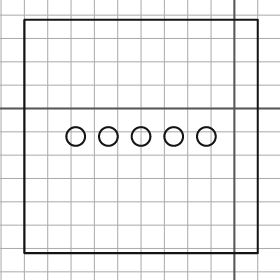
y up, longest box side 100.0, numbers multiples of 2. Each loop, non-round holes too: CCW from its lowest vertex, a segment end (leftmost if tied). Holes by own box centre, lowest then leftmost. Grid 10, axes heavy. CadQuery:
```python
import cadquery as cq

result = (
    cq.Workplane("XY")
    .moveTo(-90.0, -62.0)
    .lineTo(10.0, -62.0)
    .lineTo(10.0, 38.0)
    .lineTo(-90.0, 38.0)
    .close()
    .moveTo(-68.0, -12.0)
    .circle(4.0)
    .moveTo(-54.0, -12.0)
    .circle(4.0)
    .moveTo(-40.0, -12.0)
    .circle(4.0)
    .moveTo(-26.0, -12.0)
    .circle(4.0)
    .moveTo(-12.0, -12.0)
    .circle(4.0)
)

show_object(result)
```